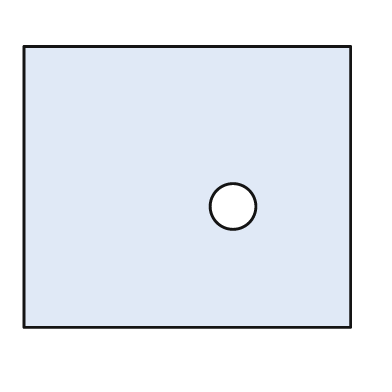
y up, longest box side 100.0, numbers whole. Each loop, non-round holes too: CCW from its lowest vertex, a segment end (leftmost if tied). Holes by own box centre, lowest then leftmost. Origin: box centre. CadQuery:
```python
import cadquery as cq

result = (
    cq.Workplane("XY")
    .moveTo(-50.0, -43.0)
    .lineTo(50.0, -43.0)
    .lineTo(50.0, 43.0)
    .lineTo(-50.0, 43.0)
    .close()
    .moveTo(14.0, -6.0)
    .circle(7.0)
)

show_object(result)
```